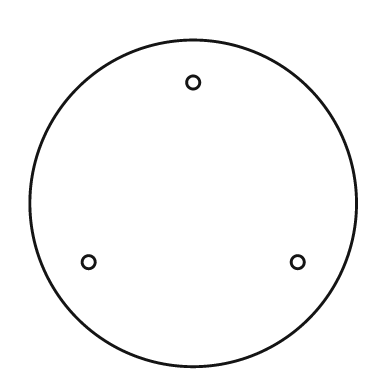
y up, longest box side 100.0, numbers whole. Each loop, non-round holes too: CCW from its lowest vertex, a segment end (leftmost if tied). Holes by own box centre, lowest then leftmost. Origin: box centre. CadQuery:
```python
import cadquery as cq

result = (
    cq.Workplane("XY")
    .moveTo(0.0, 0.0)
    .circle(50.0)
    .moveTo(-32.0, -18.0)
    .circle(2.0)
    .moveTo(32.0, -18.0)
    .circle(2.0)
    .moveTo(0.0, 37.0)
    .circle(2.0)
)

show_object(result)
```